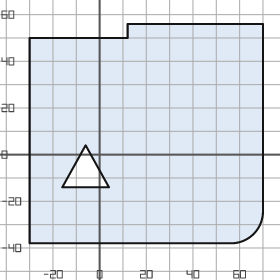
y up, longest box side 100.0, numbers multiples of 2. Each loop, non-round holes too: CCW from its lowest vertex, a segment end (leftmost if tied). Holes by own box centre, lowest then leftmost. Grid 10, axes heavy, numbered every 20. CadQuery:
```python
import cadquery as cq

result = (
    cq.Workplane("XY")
    .moveTo(-30.0, -38.0)
    .lineTo(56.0, -38.0)
    .threePointArc((66.0, -34.0), (70.0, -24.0))
    .lineTo(70.0, 56.0)
    .lineTo(12.0, 56.0)
    .lineTo(12.0, 50.0)
    .lineTo(-30.0, 50.0)
    .close()
    .moveTo(-16.0, -14.0)
    .lineTo(4.0, -14.0)
    .lineTo(-6.0, 4.0)
    .close()
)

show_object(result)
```